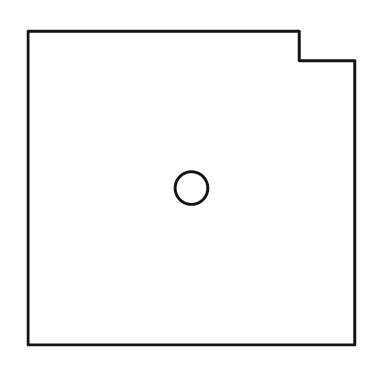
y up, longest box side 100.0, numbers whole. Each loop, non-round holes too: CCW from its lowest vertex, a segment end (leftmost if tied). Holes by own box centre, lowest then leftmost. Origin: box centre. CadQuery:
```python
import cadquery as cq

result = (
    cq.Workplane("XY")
    .moveTo(-50.0, -48.0)
    .lineTo(50.0, -48.0)
    .lineTo(50.0, 39.0)
    .lineTo(33.0, 39.0)
    .lineTo(33.0, 48.0)
    .lineTo(-50.0, 48.0)
    .close()
    .moveTo(0.0, 0.0)
    .circle(5.0)
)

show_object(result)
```